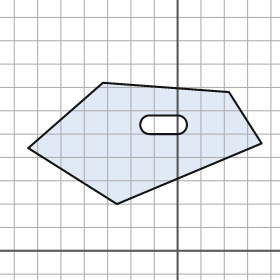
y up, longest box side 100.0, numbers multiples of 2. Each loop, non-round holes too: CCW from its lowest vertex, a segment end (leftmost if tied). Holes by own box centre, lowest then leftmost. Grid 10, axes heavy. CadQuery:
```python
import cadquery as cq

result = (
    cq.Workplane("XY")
    .moveTo(-26.0, 20.0)
    .lineTo(36.0, 46.0)
    .lineTo(22.0, 68.0)
    .lineTo(-32.0, 72.0)
    .lineTo(-64.0, 44.0)
    .close()
    .moveTo(-12.0, 50.0)
    .lineTo(0.0, 50.0)
    .threePointArc((4.0, 54.0), (0.0, 58.0))
    .lineTo(-12.0, 58.0)
    .threePointArc((-16.0, 54.0), (-12.0, 50.0))
    .close()
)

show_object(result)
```